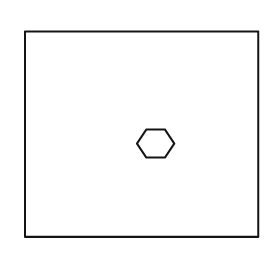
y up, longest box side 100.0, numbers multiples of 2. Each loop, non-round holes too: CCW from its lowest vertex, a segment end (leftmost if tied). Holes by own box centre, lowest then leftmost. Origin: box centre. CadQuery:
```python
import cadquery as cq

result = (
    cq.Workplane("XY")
    .moveTo(-50.0, -44.0)
    .lineTo(50.0, -44.0)
    .lineTo(50.0, 44.0)
    .lineTo(-50.0, 44.0)
    .close()
    .moveTo(2.0, -10.0)
    .lineTo(10.0, -10.0)
    .lineTo(14.0, -4.0)
    .lineTo(10.0, 2.0)
    .lineTo(2.0, 2.0)
    .lineTo(-2.0, -4.0)
    .close()
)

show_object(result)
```